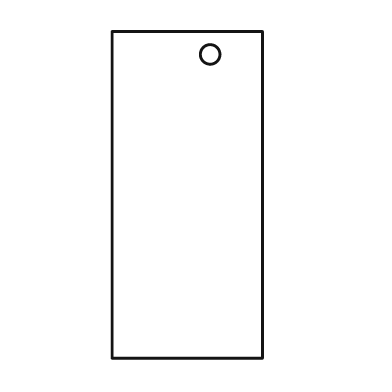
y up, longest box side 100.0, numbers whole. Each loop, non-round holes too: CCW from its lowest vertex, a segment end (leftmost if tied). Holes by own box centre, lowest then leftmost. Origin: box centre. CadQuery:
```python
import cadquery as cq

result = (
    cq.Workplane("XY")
    .moveTo(-23.0, -50.0)
    .lineTo(23.0, -50.0)
    .lineTo(23.0, 50.0)
    .lineTo(-23.0, 50.0)
    .close()
    .moveTo(7.0, 43.0)
    .circle(3.0)
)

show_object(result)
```